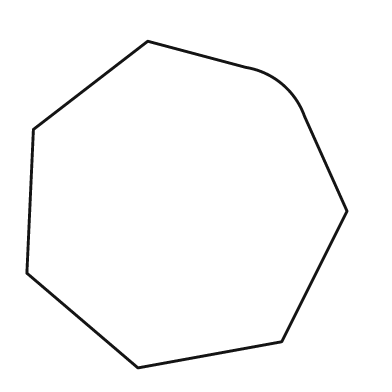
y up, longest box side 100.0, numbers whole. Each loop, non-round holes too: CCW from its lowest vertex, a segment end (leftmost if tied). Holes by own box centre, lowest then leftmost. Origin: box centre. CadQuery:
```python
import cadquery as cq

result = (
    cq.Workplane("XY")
    .moveTo(-15.0, -50.0)
    .lineTo(29.0, -42.0)
    .lineTo(49.0, -2.0)
    .lineTo(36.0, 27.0)
    .threePointArc((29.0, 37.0), (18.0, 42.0))
    .lineTo(-12.0, 50.0)
    .lineTo(-47.0, 23.0)
    .lineTo(-49.0, -21.0)
    .close()
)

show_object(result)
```